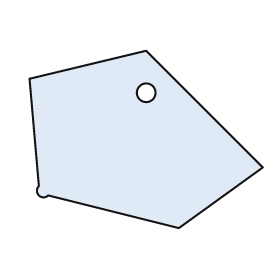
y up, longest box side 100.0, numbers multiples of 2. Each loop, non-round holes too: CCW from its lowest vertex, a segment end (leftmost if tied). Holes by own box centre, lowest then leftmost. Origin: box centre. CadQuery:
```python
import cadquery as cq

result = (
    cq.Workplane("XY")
    .moveTo(14.0, -38.0)
    .lineTo(50.0, -12.0)
    .lineTo(0.0, 38.0)
    .lineTo(-50.0, 26.0)
    .lineTo(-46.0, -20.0)
    .threePointArc((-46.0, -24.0), (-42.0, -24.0))
    .close()
    .moveTo(0.0, 20.0)
    .circle(4.0)
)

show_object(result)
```